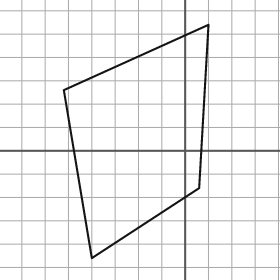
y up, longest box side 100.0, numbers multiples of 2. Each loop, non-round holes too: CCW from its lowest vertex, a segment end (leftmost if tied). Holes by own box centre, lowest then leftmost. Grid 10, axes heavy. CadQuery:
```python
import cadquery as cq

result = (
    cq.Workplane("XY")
    .moveTo(-40.0, -46.0)
    .lineTo(6.0, -16.0)
    .lineTo(10.0, 54.0)
    .lineTo(-52.0, 26.0)
    .close()
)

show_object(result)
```